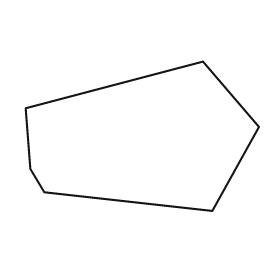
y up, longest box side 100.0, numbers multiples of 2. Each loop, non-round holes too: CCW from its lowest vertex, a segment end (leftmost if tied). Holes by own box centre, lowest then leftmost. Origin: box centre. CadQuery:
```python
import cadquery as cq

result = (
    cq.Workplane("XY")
    .moveTo(30.0, -32.0)
    .lineTo(50.0, 4.0)
    .lineTo(26.0, 32.0)
    .lineTo(-50.0, 12.0)
    .lineTo(-48.0, -14.0)
    .lineTo(-42.0, -24.0)
    .close()
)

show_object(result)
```